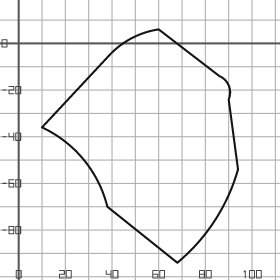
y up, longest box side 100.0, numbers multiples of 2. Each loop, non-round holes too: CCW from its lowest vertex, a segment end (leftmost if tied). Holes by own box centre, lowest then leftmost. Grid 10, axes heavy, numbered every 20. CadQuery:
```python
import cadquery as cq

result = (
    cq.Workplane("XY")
    .moveTo(68.0, -94.0)
    .threePointArc((84.0, -76.0), (94.0, -54.0))
    .lineTo(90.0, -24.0)
    .threePointArc((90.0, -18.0), (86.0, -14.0))
    .lineTo(60.0, 6.0)
    .threePointArc((48.0, 2.0), (38.0, -6.0))
    .lineTo(10.0, -36.0)
    .threePointArc((28.0, -50.0), (38.0, -70.0))
    .close()
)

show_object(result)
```